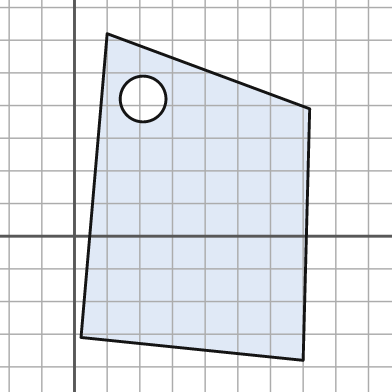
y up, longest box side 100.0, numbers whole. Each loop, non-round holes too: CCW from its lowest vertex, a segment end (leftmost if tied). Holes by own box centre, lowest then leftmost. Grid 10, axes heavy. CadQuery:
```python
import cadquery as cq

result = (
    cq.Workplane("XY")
    .moveTo(70.0, -38.0)
    .lineTo(72.0, 39.0)
    .lineTo(10.0, 62.0)
    .lineTo(2.0, -31.0)
    .close()
    .moveTo(21.0, 42.0)
    .circle(7.0)
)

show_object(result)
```